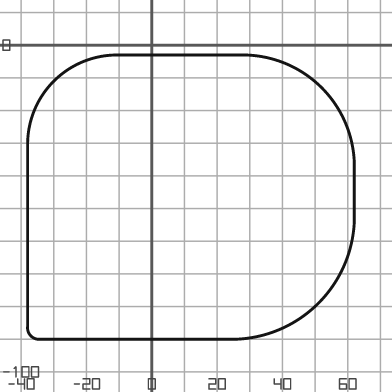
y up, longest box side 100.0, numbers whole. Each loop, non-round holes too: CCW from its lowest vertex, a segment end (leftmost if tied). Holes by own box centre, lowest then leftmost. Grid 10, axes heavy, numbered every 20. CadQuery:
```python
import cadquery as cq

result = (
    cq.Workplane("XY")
    .moveTo(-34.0, -90.0)
    .lineTo(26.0, -90.0)
    .threePointArc((51.0, -79.0), (62.0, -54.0))
    .lineTo(62.0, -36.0)
    .threePointArc((52.0, -13.0), (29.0, -3.0))
    .lineTo(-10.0, -3.0)
    .threePointArc((-30.0, -11.0), (-38.0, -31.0))
    .lineTo(-38.0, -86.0)
    .threePointArc((-37.0, -89.0), (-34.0, -90.0))
    .close()
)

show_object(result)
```